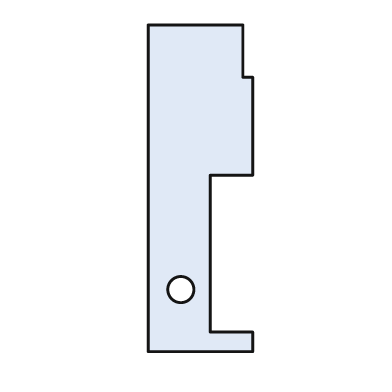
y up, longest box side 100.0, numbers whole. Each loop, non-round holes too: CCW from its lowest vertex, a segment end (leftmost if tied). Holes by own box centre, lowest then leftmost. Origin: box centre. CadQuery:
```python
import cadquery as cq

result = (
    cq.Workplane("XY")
    .moveTo(-16.0, -50.0)
    .lineTo(16.0, -50.0)
    .lineTo(16.0, -44.0)
    .lineTo(3.0, -44.0)
    .lineTo(3.0, 4.0)
    .lineTo(16.0, 4.0)
    .lineTo(16.0, 34.0)
    .lineTo(13.0, 34.0)
    .lineTo(13.0, 50.0)
    .lineTo(-16.0, 50.0)
    .close()
    .moveTo(-6.0, -31.0)
    .circle(4.0)
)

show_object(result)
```